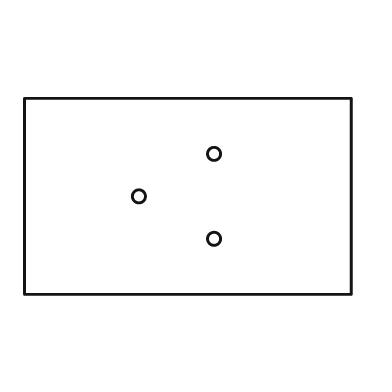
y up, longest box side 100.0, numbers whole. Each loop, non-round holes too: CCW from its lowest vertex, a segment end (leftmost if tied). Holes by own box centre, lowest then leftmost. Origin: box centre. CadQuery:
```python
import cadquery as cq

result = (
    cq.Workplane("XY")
    .moveTo(-50.0, -30.0)
    .lineTo(50.0, -30.0)
    .lineTo(50.0, 30.0)
    .lineTo(-50.0, 30.0)
    .close()
    .moveTo(8.0, -13.0)
    .circle(2.0)
    .moveTo(-15.0, 0.0)
    .circle(2.0)
    .moveTo(8.0, 13.0)
    .circle(2.0)
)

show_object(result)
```